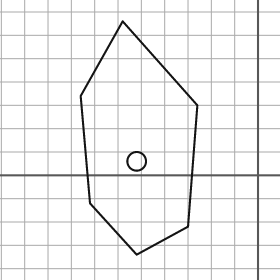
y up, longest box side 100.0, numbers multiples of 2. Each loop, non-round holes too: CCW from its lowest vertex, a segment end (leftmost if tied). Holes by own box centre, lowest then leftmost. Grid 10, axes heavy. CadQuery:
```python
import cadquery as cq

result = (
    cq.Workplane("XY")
    .moveTo(-52.0, -34.0)
    .lineTo(-30.0, -22.0)
    .lineTo(-26.0, 30.0)
    .lineTo(-58.0, 66.0)
    .lineTo(-76.0, 34.0)
    .lineTo(-72.0, -12.0)
    .close()
    .moveTo(-52.0, 6.0)
    .circle(4.0)
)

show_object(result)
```